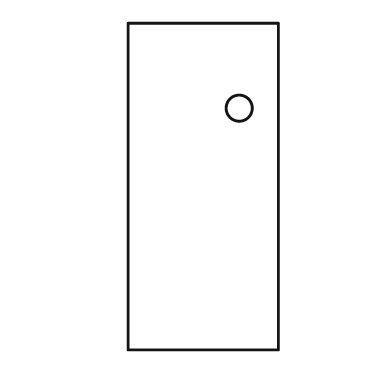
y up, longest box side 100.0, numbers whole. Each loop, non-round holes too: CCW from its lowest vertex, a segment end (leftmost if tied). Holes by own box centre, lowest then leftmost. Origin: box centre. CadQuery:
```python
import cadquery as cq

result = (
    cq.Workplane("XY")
    .moveTo(-23.0, -50.0)
    .lineTo(23.0, -50.0)
    .lineTo(23.0, 50.0)
    .lineTo(-23.0, 50.0)
    .close()
    .moveTo(11.0, 24.0)
    .circle(4.0)
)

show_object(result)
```